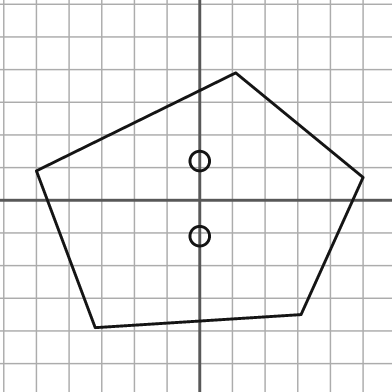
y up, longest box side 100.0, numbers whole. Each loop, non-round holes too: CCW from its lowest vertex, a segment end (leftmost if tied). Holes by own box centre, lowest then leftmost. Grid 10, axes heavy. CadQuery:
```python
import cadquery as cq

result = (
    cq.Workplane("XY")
    .moveTo(-32.0, -39.0)
    .lineTo(31.0, -35.0)
    .lineTo(50.0, 7.0)
    .lineTo(11.0, 39.0)
    .lineTo(-50.0, 9.0)
    .close()
    .moveTo(0.0, -11.0)
    .circle(3.0)
    .moveTo(0.0, 12.0)
    .circle(3.0)
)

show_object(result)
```